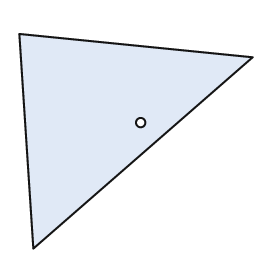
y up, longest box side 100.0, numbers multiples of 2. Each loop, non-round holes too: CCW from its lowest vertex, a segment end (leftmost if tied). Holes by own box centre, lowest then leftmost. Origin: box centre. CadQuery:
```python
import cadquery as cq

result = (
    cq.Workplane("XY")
    .moveTo(-44.0, -46.0)
    .lineTo(50.0, 36.0)
    .lineTo(-50.0, 46.0)
    .close()
    .moveTo(2.0, 8.0)
    .circle(2.0)
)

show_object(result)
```